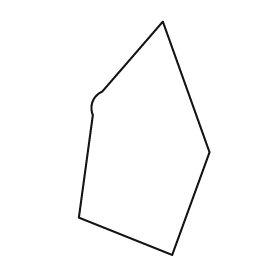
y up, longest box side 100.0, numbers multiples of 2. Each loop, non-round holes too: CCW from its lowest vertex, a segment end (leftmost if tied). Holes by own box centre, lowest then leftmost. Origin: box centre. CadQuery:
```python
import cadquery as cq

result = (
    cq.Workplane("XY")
    .moveTo(12.0, -50.0)
    .lineTo(28.0, -6.0)
    .lineTo(8.0, 50.0)
    .lineTo(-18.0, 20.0)
    .threePointArc((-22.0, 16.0), (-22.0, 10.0))
    .lineTo(-28.0, -34.0)
    .close()
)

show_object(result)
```